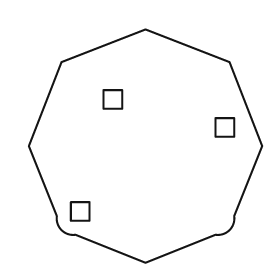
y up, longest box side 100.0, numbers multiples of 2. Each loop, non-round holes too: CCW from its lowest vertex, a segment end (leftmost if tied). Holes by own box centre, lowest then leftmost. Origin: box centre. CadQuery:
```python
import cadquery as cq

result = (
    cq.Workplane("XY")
    .moveTo(0.0, -50.0)
    .lineTo(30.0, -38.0)
    .threePointArc((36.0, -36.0), (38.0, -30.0))
    .lineTo(50.0, 0.0)
    .lineTo(36.0, 36.0)
    .lineTo(0.0, 50.0)
    .lineTo(-36.0, 36.0)
    .lineTo(-50.0, 0.0)
    .lineTo(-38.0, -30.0)
    .threePointArc((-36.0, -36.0), (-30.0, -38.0))
    .close()
    .moveTo(-32.0, -32.0)
    .lineTo(-24.0, -32.0)
    .lineTo(-24.0, -24.0)
    .lineTo(-32.0, -24.0)
    .close()
    .moveTo(30.0, 4.0)
    .lineTo(38.0, 4.0)
    .lineTo(38.0, 12.0)
    .lineTo(30.0, 12.0)
    .close()
    .moveTo(-18.0, 16.0)
    .lineTo(-10.0, 16.0)
    .lineTo(-10.0, 24.0)
    .lineTo(-18.0, 24.0)
    .close()
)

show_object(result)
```